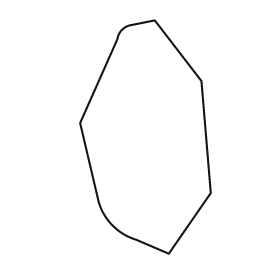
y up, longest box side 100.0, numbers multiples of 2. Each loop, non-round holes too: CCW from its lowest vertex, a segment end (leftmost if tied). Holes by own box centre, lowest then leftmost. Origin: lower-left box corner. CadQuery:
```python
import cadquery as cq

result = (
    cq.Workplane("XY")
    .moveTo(38.0, 0.0)
    .lineTo(56.0, 26.0)
    .lineTo(52.0, 74.0)
    .lineTo(32.0, 100.0)
    .lineTo(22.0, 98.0)
    .threePointArc((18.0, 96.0), (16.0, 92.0))
    .lineTo(0.0, 56.0)
    .lineTo(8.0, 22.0)
    .threePointArc((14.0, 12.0), (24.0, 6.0))
    .close()
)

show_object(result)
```